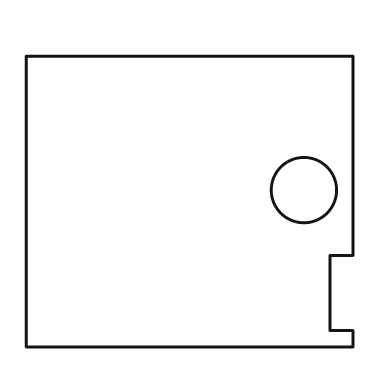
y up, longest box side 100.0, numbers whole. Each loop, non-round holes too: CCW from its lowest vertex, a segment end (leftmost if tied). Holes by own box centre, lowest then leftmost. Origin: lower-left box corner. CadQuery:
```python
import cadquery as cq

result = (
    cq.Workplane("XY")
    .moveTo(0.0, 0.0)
    .lineTo(100.0, 0.0)
    .lineTo(100.0, 5.0)
    .lineTo(93.0, 5.0)
    .lineTo(93.0, 28.0)
    .lineTo(100.0, 28.0)
    .lineTo(100.0, 89.0)
    .lineTo(0.0, 89.0)
    .close()
    .moveTo(85.0, 48.0)
    .circle(10.0)
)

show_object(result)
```